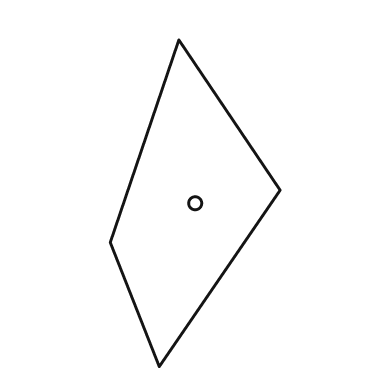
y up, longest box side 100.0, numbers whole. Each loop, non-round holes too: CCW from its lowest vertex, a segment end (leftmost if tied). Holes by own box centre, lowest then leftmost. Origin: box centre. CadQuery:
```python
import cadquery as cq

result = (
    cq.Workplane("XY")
    .moveTo(-11.0, -50.0)
    .lineTo(26.0, 4.0)
    .lineTo(-5.0, 50.0)
    .lineTo(-26.0, -12.0)
    .close()
    .moveTo(0.0, 0.0)
    .circle(2.0)
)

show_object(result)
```